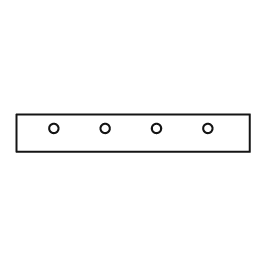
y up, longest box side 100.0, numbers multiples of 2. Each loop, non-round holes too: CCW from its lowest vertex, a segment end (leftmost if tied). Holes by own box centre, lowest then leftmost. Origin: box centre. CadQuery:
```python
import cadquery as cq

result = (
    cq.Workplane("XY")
    .moveTo(-50.0, -8.0)
    .lineTo(50.0, -8.0)
    .lineTo(50.0, 8.0)
    .lineTo(-50.0, 8.0)
    .close()
    .moveTo(-34.0, 2.0)
    .circle(2.0)
    .moveTo(-12.0, 2.0)
    .circle(2.0)
    .moveTo(10.0, 2.0)
    .circle(2.0)
    .moveTo(32.0, 2.0)
    .circle(2.0)
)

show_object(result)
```